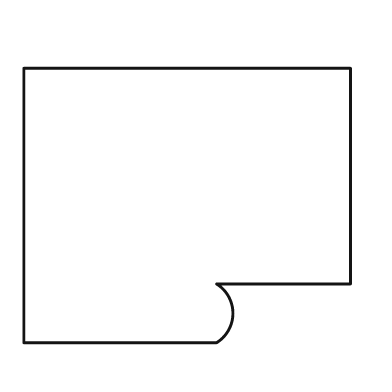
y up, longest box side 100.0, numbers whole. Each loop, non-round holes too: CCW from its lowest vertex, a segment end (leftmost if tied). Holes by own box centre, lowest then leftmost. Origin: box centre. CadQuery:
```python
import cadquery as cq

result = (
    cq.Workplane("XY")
    .moveTo(-50.0, -42.0)
    .lineTo(9.0, -42.0)
    .threePointArc((14.0, -33.0), (9.0, -24.0))
    .lineTo(50.0, -24.0)
    .lineTo(50.0, 42.0)
    .lineTo(-50.0, 42.0)
    .close()
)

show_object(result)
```